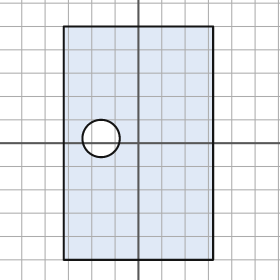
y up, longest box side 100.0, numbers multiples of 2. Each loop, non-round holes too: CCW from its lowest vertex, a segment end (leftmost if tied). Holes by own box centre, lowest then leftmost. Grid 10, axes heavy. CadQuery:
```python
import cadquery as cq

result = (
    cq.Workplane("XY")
    .moveTo(-32.0, -50.0)
    .lineTo(32.0, -50.0)
    .lineTo(32.0, 50.0)
    .lineTo(-32.0, 50.0)
    .close()
    .moveTo(-16.0, 2.0)
    .circle(8.0)
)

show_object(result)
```